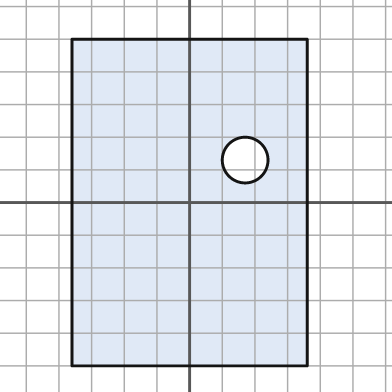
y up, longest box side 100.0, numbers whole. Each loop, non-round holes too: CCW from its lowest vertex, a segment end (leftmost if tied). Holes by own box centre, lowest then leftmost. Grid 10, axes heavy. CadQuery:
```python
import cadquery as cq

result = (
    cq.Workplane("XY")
    .moveTo(-36.0, -50.0)
    .lineTo(36.0, -50.0)
    .lineTo(36.0, 50.0)
    .lineTo(-36.0, 50.0)
    .close()
    .moveTo(17.0, 13.0)
    .circle(7.0)
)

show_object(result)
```